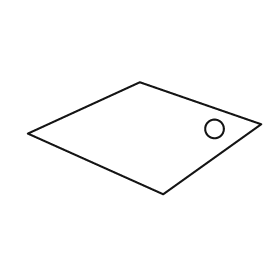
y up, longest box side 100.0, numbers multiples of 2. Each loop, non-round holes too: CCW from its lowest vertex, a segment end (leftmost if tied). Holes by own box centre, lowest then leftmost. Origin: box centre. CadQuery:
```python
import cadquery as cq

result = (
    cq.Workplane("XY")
    .moveTo(8.0, -24.0)
    .lineTo(50.0, 6.0)
    .lineTo(-2.0, 24.0)
    .lineTo(-50.0, 2.0)
    .close()
    .moveTo(30.0, 4.0)
    .circle(4.0)
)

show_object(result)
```